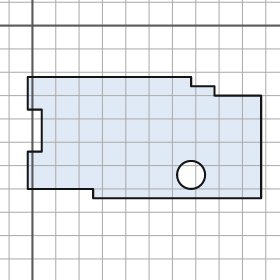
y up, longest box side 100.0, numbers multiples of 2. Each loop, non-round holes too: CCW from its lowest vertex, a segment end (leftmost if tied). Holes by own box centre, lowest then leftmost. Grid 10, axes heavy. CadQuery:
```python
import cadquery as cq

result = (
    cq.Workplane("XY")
    .moveTo(26.0, -74.0)
    .lineTo(98.0, -74.0)
    .lineTo(98.0, -30.0)
    .lineTo(78.0, -30.0)
    .lineTo(78.0, -26.0)
    .lineTo(68.0, -26.0)
    .lineTo(68.0, -22.0)
    .lineTo(-2.0, -22.0)
    .lineTo(-2.0, -36.0)
    .lineTo(4.0, -36.0)
    .lineTo(4.0, -54.0)
    .lineTo(-2.0, -54.0)
    .lineTo(-2.0, -70.0)
    .lineTo(26.0, -70.0)
    .close()
    .moveTo(68.0, -64.0)
    .circle(6.0)
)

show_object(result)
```